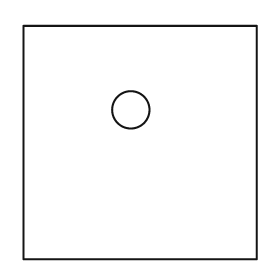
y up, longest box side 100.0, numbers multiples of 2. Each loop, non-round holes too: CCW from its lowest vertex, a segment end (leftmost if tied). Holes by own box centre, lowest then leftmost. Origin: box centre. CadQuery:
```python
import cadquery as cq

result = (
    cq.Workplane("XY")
    .moveTo(-50.0, -50.0)
    .lineTo(50.0, -50.0)
    .lineTo(50.0, 50.0)
    .lineTo(-50.0, 50.0)
    .close()
    .moveTo(-4.0, 14.0)
    .circle(8.0)
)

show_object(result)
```